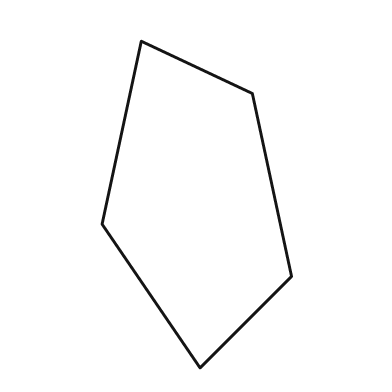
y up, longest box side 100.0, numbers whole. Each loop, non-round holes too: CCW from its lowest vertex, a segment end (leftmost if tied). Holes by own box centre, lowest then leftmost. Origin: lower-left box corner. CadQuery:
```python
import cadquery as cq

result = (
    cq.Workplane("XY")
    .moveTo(30.0, 0.0)
    .lineTo(58.0, 28.0)
    .lineTo(46.0, 84.0)
    .lineTo(12.0, 100.0)
    .lineTo(0.0, 44.0)
    .close()
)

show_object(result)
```